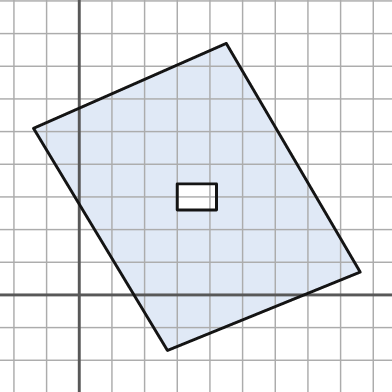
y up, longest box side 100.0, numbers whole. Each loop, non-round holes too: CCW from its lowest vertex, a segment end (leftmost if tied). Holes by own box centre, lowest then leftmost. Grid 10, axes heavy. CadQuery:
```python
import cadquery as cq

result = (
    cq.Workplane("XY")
    .moveTo(27.0, -17.0)
    .lineTo(86.0, 7.0)
    .lineTo(45.0, 77.0)
    .lineTo(-14.0, 51.0)
    .close()
    .moveTo(30.0, 26.0)
    .lineTo(42.0, 26.0)
    .lineTo(42.0, 34.0)
    .lineTo(30.0, 34.0)
    .close()
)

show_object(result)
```